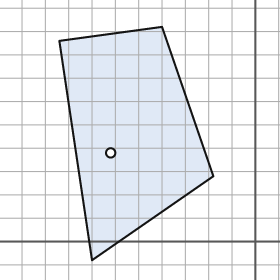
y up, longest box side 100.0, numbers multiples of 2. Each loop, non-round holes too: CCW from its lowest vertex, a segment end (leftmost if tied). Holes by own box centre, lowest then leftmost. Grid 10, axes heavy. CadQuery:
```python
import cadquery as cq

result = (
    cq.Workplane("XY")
    .moveTo(-70.0, -8.0)
    .lineTo(-18.0, 28.0)
    .lineTo(-40.0, 92.0)
    .lineTo(-84.0, 86.0)
    .close()
    .moveTo(-62.0, 38.0)
    .circle(2.0)
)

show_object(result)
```